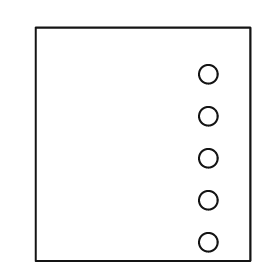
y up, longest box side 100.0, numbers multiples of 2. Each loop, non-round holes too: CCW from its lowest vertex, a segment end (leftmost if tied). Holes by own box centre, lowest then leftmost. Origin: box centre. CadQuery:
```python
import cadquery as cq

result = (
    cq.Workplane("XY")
    .moveTo(-46.0, -50.0)
    .lineTo(46.0, -50.0)
    .lineTo(46.0, 50.0)
    .lineTo(-46.0, 50.0)
    .close()
    .moveTo(28.0, -42.0)
    .circle(4.0)
    .moveTo(28.0, -24.0)
    .circle(4.0)
    .moveTo(28.0, -6.0)
    .circle(4.0)
    .moveTo(28.0, 12.0)
    .circle(4.0)
    .moveTo(28.0, 30.0)
    .circle(4.0)
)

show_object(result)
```